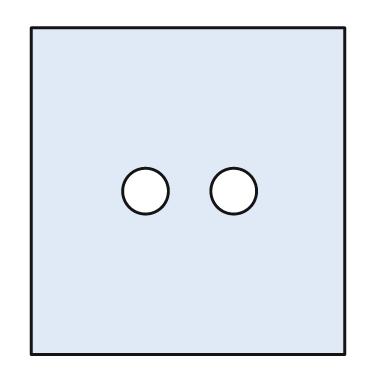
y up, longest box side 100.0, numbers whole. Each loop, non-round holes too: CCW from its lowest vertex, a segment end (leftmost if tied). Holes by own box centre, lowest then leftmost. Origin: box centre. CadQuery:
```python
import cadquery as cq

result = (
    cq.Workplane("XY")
    .moveTo(-48.0, -50.0)
    .lineTo(48.0, -50.0)
    .lineTo(48.0, 50.0)
    .lineTo(-48.0, 50.0)
    .close()
    .moveTo(-13.0, 0.0)
    .circle(7.0)
    .moveTo(14.0, 0.0)
    .circle(7.0)
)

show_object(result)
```